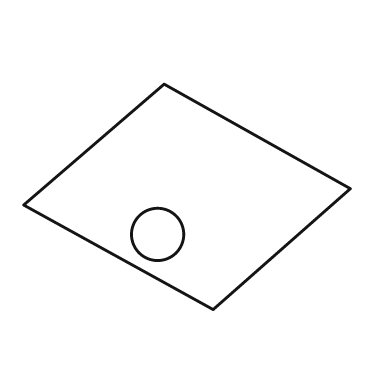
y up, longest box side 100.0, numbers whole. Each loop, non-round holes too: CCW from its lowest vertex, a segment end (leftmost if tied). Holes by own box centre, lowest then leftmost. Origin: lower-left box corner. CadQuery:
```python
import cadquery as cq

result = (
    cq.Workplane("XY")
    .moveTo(58.0, 0.0)
    .lineTo(100.0, 37.0)
    .lineTo(43.0, 69.0)
    .lineTo(0.0, 32.0)
    .close()
    .moveTo(41.0, 23.0)
    .circle(8.0)
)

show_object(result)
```